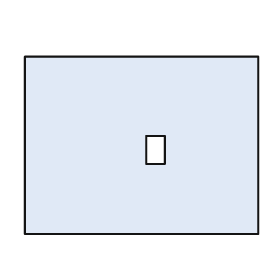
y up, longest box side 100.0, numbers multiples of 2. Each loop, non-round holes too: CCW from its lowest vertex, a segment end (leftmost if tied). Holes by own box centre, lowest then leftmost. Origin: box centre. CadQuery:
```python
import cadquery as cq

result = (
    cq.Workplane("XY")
    .moveTo(-50.0, -38.0)
    .lineTo(50.0, -38.0)
    .lineTo(50.0, 38.0)
    .lineTo(-50.0, 38.0)
    .close()
    .moveTo(2.0, -8.0)
    .lineTo(10.0, -8.0)
    .lineTo(10.0, 4.0)
    .lineTo(2.0, 4.0)
    .close()
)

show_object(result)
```